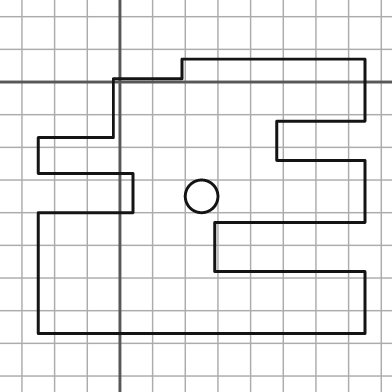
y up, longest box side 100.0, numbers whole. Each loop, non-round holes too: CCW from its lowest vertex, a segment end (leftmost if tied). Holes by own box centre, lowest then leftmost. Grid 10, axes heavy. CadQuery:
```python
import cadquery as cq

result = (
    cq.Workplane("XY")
    .moveTo(-25.0, -77.0)
    .lineTo(75.0, -77.0)
    .lineTo(75.0, -58.0)
    .lineTo(29.0, -58.0)
    .lineTo(29.0, -43.0)
    .lineTo(75.0, -43.0)
    .lineTo(75.0, -24.0)
    .lineTo(48.0, -24.0)
    .lineTo(48.0, -12.0)
    .lineTo(75.0, -12.0)
    .lineTo(75.0, 7.0)
    .lineTo(19.0, 7.0)
    .lineTo(19.0, 1.0)
    .lineTo(-2.0, 1.0)
    .lineTo(-2.0, -17.0)
    .lineTo(-25.0, -17.0)
    .lineTo(-25.0, -28.0)
    .lineTo(4.0, -28.0)
    .lineTo(4.0, -40.0)
    .lineTo(-25.0, -40.0)
    .close()
    .moveTo(25.0, -35.0)
    .circle(5.0)
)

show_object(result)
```